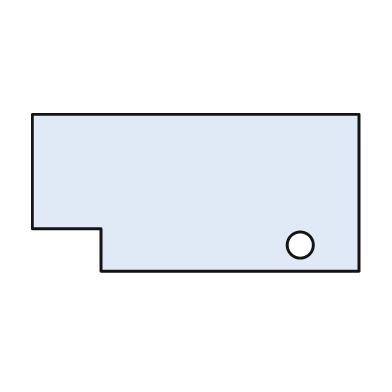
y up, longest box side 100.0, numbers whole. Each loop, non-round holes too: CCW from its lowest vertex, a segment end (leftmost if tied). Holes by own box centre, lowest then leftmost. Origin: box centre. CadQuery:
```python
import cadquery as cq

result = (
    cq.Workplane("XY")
    .moveTo(-29.0, -24.0)
    .lineTo(50.0, -24.0)
    .lineTo(50.0, 24.0)
    .lineTo(-50.0, 24.0)
    .lineTo(-50.0, -11.0)
    .lineTo(-29.0, -11.0)
    .close()
    .moveTo(32.0, -16.0)
    .circle(4.0)
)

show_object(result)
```